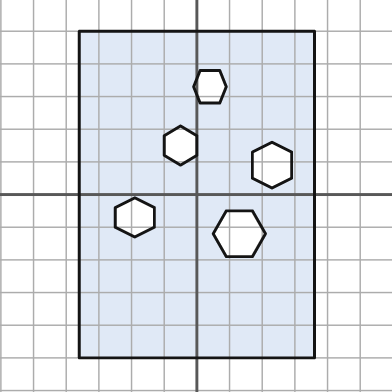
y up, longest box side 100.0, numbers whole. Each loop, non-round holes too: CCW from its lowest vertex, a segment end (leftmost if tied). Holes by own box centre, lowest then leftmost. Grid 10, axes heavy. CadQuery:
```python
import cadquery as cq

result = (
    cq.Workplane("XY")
    .moveTo(-36.0, -50.0)
    .lineTo(36.0, -50.0)
    .lineTo(36.0, 50.0)
    .lineTo(-36.0, 50.0)
    .close()
    .moveTo(9.0, -19.0)
    .lineTo(17.0, -19.0)
    .lineTo(21.0, -12.0)
    .lineTo(17.0, -5.0)
    .lineTo(9.0, -5.0)
    .lineTo(5.0, -12.0)
    .close()
    .moveTo(-19.0, -13.0)
    .lineTo(-13.0, -10.0)
    .lineTo(-13.0, -4.0)
    .lineTo(-19.0, -1.0)
    .lineTo(-25.0, -4.0)
    .lineTo(-25.0, -10.0)
    .close()
    .moveTo(23.0, 2.0)
    .lineTo(29.0, 5.0)
    .lineTo(29.0, 13.0)
    .lineTo(23.0, 16.0)
    .lineTo(17.0, 13.0)
    .lineTo(17.0, 5.0)
    .close()
    .moveTo(-5.0, 9.0)
    .lineTo(0.0, 12.0)
    .lineTo(0.0, 18.0)
    .lineTo(-5.0, 21.0)
    .lineTo(-10.0, 18.0)
    .lineTo(-10.0, 12.0)
    .close()
    .moveTo(1.0, 28.0)
    .lineTo(7.0, 28.0)
    .lineTo(9.0, 33.0)
    .lineTo(7.0, 38.0)
    .lineTo(1.0, 38.0)
    .lineTo(-1.0, 33.0)
    .close()
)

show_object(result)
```